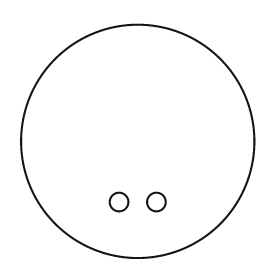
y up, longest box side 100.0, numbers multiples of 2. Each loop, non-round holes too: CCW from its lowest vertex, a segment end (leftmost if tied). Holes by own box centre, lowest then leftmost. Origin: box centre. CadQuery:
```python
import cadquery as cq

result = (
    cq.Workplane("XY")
    .moveTo(0.0, 0.0)
    .circle(50.0)
    .moveTo(-8.0, -26.0)
    .circle(4.0)
    .moveTo(8.0, -26.0)
    .circle(4.0)
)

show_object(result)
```